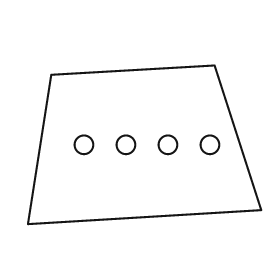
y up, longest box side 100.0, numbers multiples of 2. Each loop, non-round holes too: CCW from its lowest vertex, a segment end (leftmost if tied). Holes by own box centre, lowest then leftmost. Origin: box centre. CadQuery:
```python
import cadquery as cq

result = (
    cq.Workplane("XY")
    .moveTo(-50.0, -34.0)
    .lineTo(50.0, -28.0)
    .lineTo(30.0, 34.0)
    .lineTo(-40.0, 30.0)
    .close()
    .moveTo(-26.0, 0.0)
    .circle(4.0)
    .moveTo(-8.0, 0.0)
    .circle(4.0)
    .moveTo(10.0, 0.0)
    .circle(4.0)
    .moveTo(28.0, 0.0)
    .circle(4.0)
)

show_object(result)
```